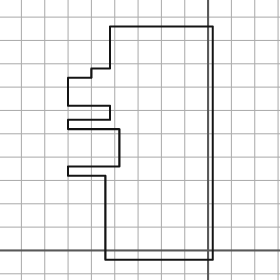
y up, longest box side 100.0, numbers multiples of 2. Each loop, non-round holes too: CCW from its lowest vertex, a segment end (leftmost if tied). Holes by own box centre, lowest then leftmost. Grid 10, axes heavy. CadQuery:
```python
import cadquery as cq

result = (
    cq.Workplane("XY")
    .moveTo(-44.0, -4.0)
    .lineTo(2.0, -4.0)
    .lineTo(2.0, 96.0)
    .lineTo(-42.0, 96.0)
    .lineTo(-42.0, 78.0)
    .lineTo(-50.0, 78.0)
    .lineTo(-50.0, 74.0)
    .lineTo(-60.0, 74.0)
    .lineTo(-60.0, 62.0)
    .lineTo(-42.0, 62.0)
    .lineTo(-42.0, 56.0)
    .lineTo(-60.0, 56.0)
    .lineTo(-60.0, 52.0)
    .lineTo(-38.0, 52.0)
    .lineTo(-38.0, 36.0)
    .lineTo(-60.0, 36.0)
    .lineTo(-60.0, 32.0)
    .lineTo(-44.0, 32.0)
    .close()
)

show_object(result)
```